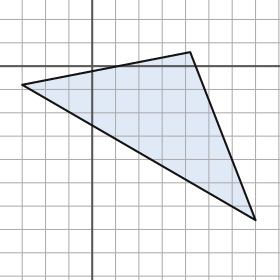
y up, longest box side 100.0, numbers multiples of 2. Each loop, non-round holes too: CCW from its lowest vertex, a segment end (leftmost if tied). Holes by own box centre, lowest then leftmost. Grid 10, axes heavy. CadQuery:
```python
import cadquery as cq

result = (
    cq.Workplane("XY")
    .moveTo(70.0, -66.0)
    .lineTo(42.0, 6.0)
    .lineTo(-30.0, -8.0)
    .close()
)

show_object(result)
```